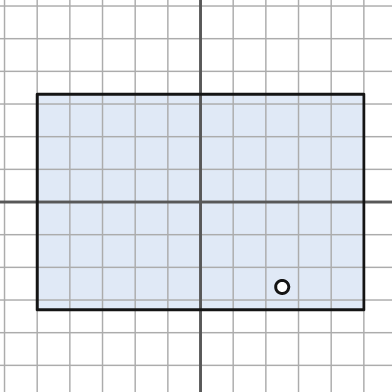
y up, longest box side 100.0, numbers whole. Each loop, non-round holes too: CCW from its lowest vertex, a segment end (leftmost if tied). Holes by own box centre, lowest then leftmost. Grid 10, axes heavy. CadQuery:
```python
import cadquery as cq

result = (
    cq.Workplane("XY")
    .moveTo(-50.0, -33.0)
    .lineTo(50.0, -33.0)
    .lineTo(50.0, 33.0)
    .lineTo(-50.0, 33.0)
    .close()
    .moveTo(25.0, -26.0)
    .circle(2.0)
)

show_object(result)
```